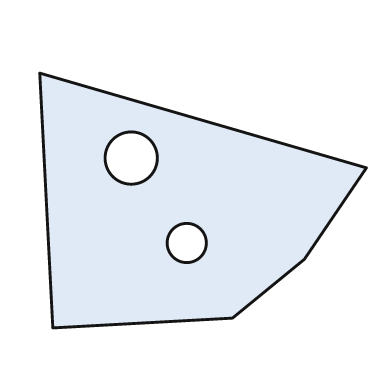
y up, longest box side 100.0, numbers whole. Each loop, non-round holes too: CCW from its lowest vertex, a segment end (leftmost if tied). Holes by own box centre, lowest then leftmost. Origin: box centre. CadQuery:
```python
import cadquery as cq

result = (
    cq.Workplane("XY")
    .moveTo(-46.0, -39.0)
    .lineTo(9.0, -36.0)
    .lineTo(31.0, -18.0)
    .lineTo(50.0, 10.0)
    .lineTo(-50.0, 39.0)
    .close()
    .moveTo(-5.0, -13.0)
    .circle(6.0)
    .moveTo(-22.0, 13.0)
    .circle(8.0)
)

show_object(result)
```